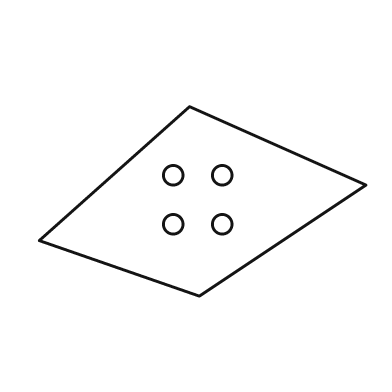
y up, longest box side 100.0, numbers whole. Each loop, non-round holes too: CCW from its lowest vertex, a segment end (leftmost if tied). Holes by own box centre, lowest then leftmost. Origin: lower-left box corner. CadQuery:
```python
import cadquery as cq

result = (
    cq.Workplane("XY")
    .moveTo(49.0, 0.0)
    .lineTo(100.0, 34.0)
    .lineTo(46.0, 58.0)
    .lineTo(0.0, 17.0)
    .close()
    .moveTo(41.0, 22.0)
    .circle(3.0)
    .moveTo(56.0, 22.0)
    .circle(3.0)
    .moveTo(41.0, 37.0)
    .circle(3.0)
    .moveTo(56.0, 37.0)
    .circle(3.0)
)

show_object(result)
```